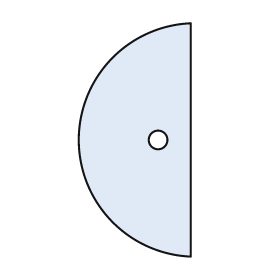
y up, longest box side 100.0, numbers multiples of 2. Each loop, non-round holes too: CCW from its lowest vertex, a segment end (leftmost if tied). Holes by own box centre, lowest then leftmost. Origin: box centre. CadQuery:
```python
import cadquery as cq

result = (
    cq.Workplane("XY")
    .moveTo(24.0, -50.0)
    .lineTo(24.0, 50.0)
    .threePointArc((-24.0, 0.0), (24.0, -50.0))
    .close()
    .moveTo(10.0, 0.0)
    .circle(4.0)
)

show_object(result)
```